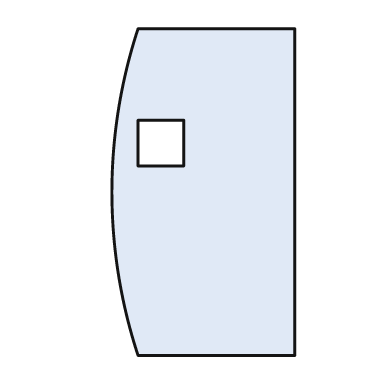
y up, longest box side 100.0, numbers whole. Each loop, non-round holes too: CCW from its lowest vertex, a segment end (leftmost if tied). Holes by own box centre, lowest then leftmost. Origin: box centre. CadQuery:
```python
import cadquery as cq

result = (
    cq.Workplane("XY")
    .moveTo(-20.0, -50.0)
    .lineTo(28.0, -50.0)
    .lineTo(28.0, 50.0)
    .lineTo(-20.0, 50.0)
    .threePointArc((-28.0, 0.0), (-20.0, -50.0))
    .close()
    .moveTo(-20.0, 8.0)
    .lineTo(-6.0, 8.0)
    .lineTo(-6.0, 22.0)
    .lineTo(-20.0, 22.0)
    .close()
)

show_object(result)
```